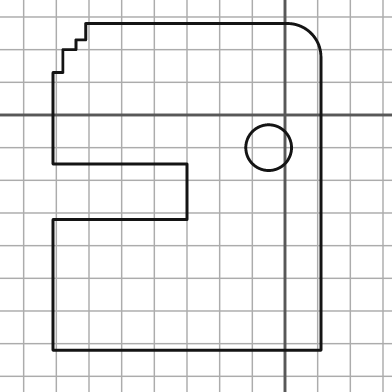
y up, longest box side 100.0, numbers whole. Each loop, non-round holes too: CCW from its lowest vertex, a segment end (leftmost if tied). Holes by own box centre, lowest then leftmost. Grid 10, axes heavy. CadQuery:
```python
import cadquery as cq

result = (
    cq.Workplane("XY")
    .moveTo(-71.0, -72.0)
    .lineTo(11.0, -72.0)
    .lineTo(11.0, 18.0)
    .threePointArc((8.0, 25.0), (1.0, 28.0))
    .lineTo(-61.0, 28.0)
    .lineTo(-61.0, 23.0)
    .lineTo(-64.0, 23.0)
    .lineTo(-64.0, 20.0)
    .lineTo(-68.0, 20.0)
    .lineTo(-68.0, 13.0)
    .lineTo(-71.0, 13.0)
    .lineTo(-71.0, -15.0)
    .lineTo(-30.0, -15.0)
    .lineTo(-30.0, -32.0)
    .lineTo(-71.0, -32.0)
    .close()
    .moveTo(-5.0, -10.0)
    .circle(7.0)
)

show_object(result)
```